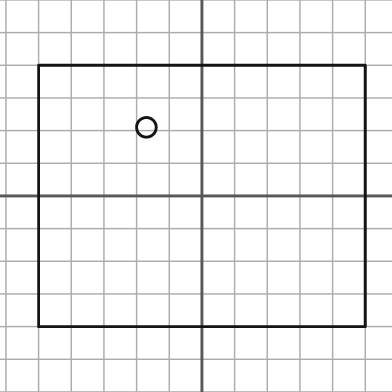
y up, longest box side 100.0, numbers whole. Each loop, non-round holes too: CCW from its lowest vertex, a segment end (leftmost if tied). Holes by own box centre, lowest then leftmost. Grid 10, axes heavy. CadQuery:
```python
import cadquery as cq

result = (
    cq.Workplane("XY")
    .moveTo(-50.0, -40.0)
    .lineTo(50.0, -40.0)
    .lineTo(50.0, 40.0)
    .lineTo(-50.0, 40.0)
    .close()
    .moveTo(-17.0, 21.0)
    .circle(3.0)
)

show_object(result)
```